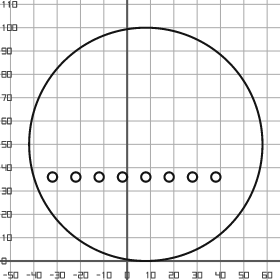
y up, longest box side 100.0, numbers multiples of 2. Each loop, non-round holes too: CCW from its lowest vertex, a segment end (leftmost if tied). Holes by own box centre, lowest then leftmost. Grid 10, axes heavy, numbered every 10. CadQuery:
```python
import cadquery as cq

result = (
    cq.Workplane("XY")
    .moveTo(8.0, 50.0)
    .circle(50.0)
    .moveTo(-32.0, 36.0)
    .circle(2.0)
    .moveTo(-22.0, 36.0)
    .circle(2.0)
    .moveTo(-12.0, 36.0)
    .circle(2.0)
    .moveTo(-2.0, 36.0)
    .circle(2.0)
    .moveTo(8.0, 36.0)
    .circle(2.0)
    .moveTo(18.0, 36.0)
    .circle(2.0)
    .moveTo(28.0, 36.0)
    .circle(2.0)
    .moveTo(38.0, 36.0)
    .circle(2.0)
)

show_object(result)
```